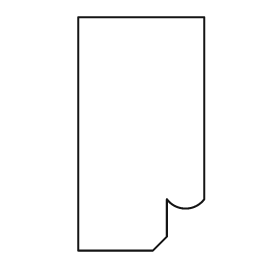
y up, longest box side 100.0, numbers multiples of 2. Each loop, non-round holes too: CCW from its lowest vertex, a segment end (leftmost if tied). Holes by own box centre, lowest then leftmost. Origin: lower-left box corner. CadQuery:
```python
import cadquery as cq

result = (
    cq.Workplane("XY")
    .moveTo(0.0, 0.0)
    .lineTo(32.0, 0.0)
    .lineTo(38.0, 6.0)
    .lineTo(38.0, 22.0)
    .threePointArc((46.0, 18.0), (54.0, 22.0))
    .lineTo(54.0, 100.0)
    .lineTo(0.0, 100.0)
    .close()
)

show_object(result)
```